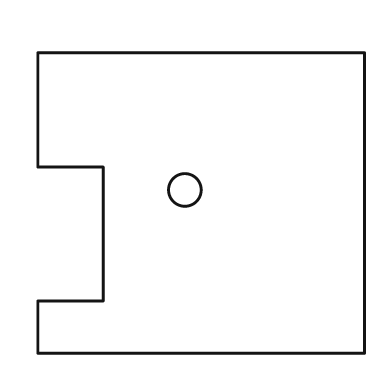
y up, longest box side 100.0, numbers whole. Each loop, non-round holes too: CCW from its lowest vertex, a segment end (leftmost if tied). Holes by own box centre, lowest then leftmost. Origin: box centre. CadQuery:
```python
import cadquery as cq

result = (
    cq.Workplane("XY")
    .moveTo(-50.0, -46.0)
    .lineTo(50.0, -46.0)
    .lineTo(50.0, 46.0)
    .lineTo(-50.0, 46.0)
    .lineTo(-50.0, 11.0)
    .lineTo(-30.0, 11.0)
    .lineTo(-30.0, -30.0)
    .lineTo(-50.0, -30.0)
    .close()
    .moveTo(-5.0, 4.0)
    .circle(5.0)
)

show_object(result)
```